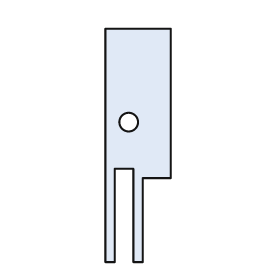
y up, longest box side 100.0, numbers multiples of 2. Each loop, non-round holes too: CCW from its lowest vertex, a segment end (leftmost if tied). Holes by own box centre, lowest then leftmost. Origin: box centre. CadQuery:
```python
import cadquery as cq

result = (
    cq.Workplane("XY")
    .moveTo(-14.0, -50.0)
    .lineTo(-10.0, -50.0)
    .lineTo(-10.0, -10.0)
    .lineTo(-2.0, -10.0)
    .lineTo(-2.0, -50.0)
    .lineTo(2.0, -50.0)
    .lineTo(2.0, -14.0)
    .lineTo(14.0, -14.0)
    .lineTo(14.0, 50.0)
    .lineTo(-14.0, 50.0)
    .close()
    .moveTo(-4.0, 10.0)
    .circle(4.0)
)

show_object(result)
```